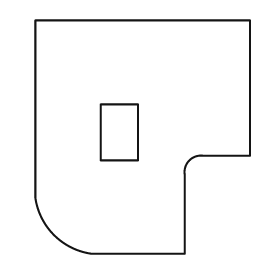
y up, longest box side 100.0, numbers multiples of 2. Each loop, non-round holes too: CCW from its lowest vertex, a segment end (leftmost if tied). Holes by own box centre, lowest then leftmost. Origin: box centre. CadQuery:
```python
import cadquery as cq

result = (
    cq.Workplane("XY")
    .moveTo(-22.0, -50.0)
    .lineTo(18.0, -50.0)
    .lineTo(18.0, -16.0)
    .threePointArc((20.0, -10.0), (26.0, -8.0))
    .lineTo(46.0, -8.0)
    .lineTo(46.0, 50.0)
    .lineTo(-46.0, 50.0)
    .lineTo(-46.0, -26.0)
    .threePointArc((-38.0, -42.0), (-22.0, -50.0))
    .close()
    .moveTo(-18.0, -10.0)
    .lineTo(-2.0, -10.0)
    .lineTo(-2.0, 14.0)
    .lineTo(-18.0, 14.0)
    .close()
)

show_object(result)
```